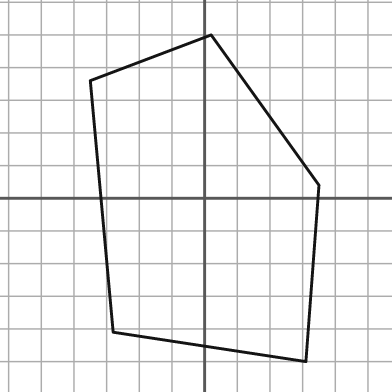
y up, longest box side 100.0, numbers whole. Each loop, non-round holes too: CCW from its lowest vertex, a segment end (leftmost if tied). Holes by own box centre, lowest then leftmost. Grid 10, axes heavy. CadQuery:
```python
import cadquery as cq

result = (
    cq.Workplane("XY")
    .moveTo(31.0, -50.0)
    .lineTo(35.0, 4.0)
    .lineTo(2.0, 50.0)
    .lineTo(-35.0, 36.0)
    .lineTo(-28.0, -41.0)
    .close()
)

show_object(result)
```